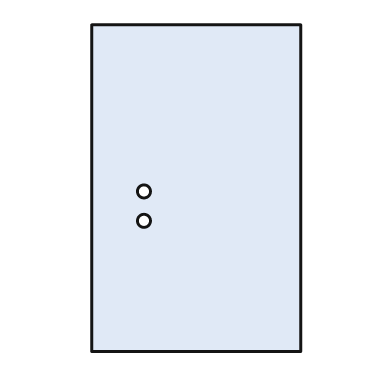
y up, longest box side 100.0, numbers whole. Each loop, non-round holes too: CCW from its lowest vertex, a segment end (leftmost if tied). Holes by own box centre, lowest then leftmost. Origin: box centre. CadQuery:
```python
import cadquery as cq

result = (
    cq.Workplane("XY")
    .moveTo(-32.0, -50.0)
    .lineTo(32.0, -50.0)
    .lineTo(32.0, 50.0)
    .lineTo(-32.0, 50.0)
    .close()
    .moveTo(-16.0, -10.0)
    .circle(2.0)
    .moveTo(-16.0, -1.0)
    .circle(2.0)
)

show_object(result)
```